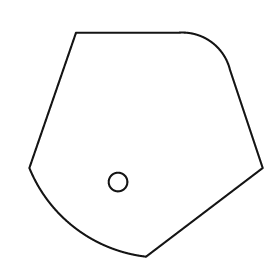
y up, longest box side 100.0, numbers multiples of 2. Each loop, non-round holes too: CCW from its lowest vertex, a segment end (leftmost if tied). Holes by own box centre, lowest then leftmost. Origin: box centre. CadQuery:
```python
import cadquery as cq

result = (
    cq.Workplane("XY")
    .moveTo(0.0, -48.0)
    .lineTo(50.0, -10.0)
    .lineTo(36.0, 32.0)
    .threePointArc((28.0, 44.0), (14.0, 48.0))
    .lineTo(-30.0, 48.0)
    .lineTo(-50.0, -10.0)
    .threePointArc((-30.0, -36.0), (0.0, -48.0))
    .close()
    .moveTo(-12.0, -16.0)
    .circle(4.0)
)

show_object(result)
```